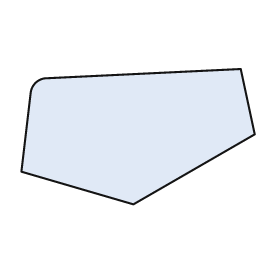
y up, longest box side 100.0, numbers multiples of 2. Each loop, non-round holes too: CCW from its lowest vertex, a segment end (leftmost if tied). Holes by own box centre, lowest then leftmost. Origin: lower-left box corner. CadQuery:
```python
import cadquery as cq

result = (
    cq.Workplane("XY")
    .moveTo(48.0, 0.0)
    .lineTo(100.0, 30.0)
    .lineTo(94.0, 58.0)
    .lineTo(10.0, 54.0)
    .threePointArc((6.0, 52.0), (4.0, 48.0))
    .lineTo(0.0, 14.0)
    .close()
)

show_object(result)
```